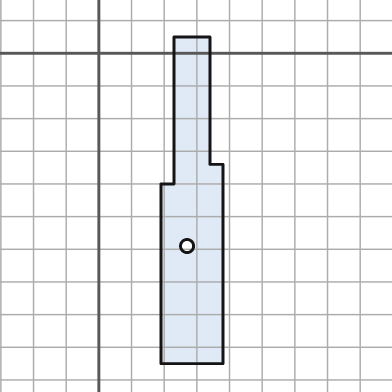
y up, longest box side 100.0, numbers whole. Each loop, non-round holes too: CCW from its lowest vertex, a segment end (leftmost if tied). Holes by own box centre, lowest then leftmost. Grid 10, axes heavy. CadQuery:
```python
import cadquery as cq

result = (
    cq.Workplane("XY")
    .moveTo(19.0, -95.0)
    .lineTo(38.0, -95.0)
    .lineTo(38.0, -34.0)
    .lineTo(34.0, -34.0)
    .lineTo(34.0, 5.0)
    .lineTo(23.0, 5.0)
    .lineTo(23.0, -40.0)
    .lineTo(19.0, -40.0)
    .close()
    .moveTo(27.0, -59.0)
    .circle(2.0)
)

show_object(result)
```